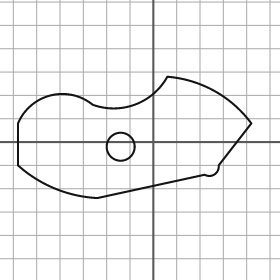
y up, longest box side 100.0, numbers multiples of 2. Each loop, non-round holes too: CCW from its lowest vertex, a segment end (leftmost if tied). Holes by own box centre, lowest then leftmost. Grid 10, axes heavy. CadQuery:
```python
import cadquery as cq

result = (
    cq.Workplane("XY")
    .moveTo(-24.0, -24.0)
    .lineTo(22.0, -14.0)
    .threePointArc((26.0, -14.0), (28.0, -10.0))
    .lineTo(42.0, 8.0)
    .threePointArc((26.0, 22.0), (6.0, 28.0))
    .threePointArc((-8.0, 16.0), (-26.0, 16.0))
    .threePointArc((-44.0, 20.0), (-58.0, 8.0))
    .lineTo(-58.0, -10.0)
    .threePointArc((-42.0, -20.0), (-24.0, -24.0))
    .close()
    .moveTo(-14.0, -2.0)
    .circle(6.0)
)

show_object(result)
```